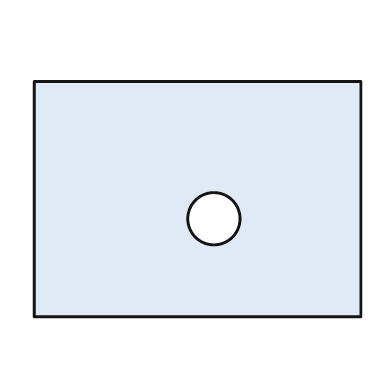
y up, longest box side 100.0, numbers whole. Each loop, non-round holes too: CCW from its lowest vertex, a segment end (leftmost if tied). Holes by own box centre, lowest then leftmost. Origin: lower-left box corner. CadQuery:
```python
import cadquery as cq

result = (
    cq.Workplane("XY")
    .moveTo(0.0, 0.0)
    .lineTo(100.0, 0.0)
    .lineTo(100.0, 72.0)
    .lineTo(0.0, 72.0)
    .close()
    .moveTo(55.0, 30.0)
    .circle(8.0)
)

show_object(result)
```